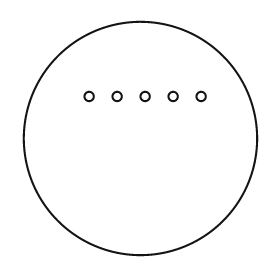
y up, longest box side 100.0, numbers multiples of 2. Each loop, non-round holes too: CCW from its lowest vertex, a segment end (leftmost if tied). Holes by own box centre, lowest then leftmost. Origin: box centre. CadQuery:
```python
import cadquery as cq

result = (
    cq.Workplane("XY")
    .moveTo(0.0, 0.0)
    .circle(50.0)
    .moveTo(-22.0, 18.0)
    .circle(2.0)
    .moveTo(-10.0, 18.0)
    .circle(2.0)
    .moveTo(2.0, 18.0)
    .circle(2.0)
    .moveTo(14.0, 18.0)
    .circle(2.0)
    .moveTo(26.0, 18.0)
    .circle(2.0)
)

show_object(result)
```